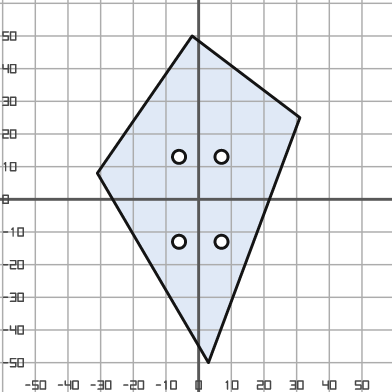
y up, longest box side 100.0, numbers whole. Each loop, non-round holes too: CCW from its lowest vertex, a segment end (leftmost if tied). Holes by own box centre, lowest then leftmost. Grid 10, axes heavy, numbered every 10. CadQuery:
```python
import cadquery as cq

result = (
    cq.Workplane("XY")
    .moveTo(3.0, -50.0)
    .lineTo(31.0, 25.0)
    .lineTo(-2.0, 50.0)
    .lineTo(-31.0, 8.0)
    .close()
    .moveTo(-6.0, -13.0)
    .circle(2.0)
    .moveTo(7.0, -13.0)
    .circle(2.0)
    .moveTo(-6.0, 13.0)
    .circle(2.0)
    .moveTo(7.0, 13.0)
    .circle(2.0)
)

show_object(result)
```